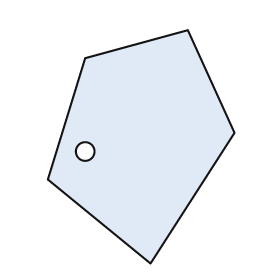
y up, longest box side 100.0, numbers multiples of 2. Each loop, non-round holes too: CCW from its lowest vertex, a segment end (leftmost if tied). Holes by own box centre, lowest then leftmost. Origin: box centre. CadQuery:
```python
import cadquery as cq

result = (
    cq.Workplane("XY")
    .moveTo(4.0, -50.0)
    .lineTo(40.0, 6.0)
    .lineTo(20.0, 50.0)
    .lineTo(-24.0, 38.0)
    .lineTo(-40.0, -14.0)
    .close()
    .moveTo(-24.0, -2.0)
    .circle(4.0)
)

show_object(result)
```